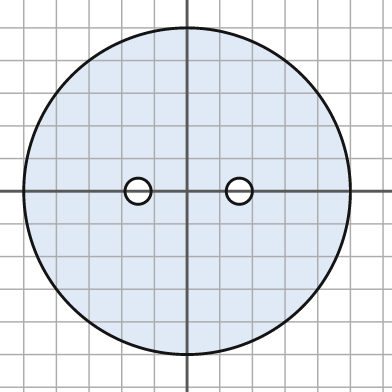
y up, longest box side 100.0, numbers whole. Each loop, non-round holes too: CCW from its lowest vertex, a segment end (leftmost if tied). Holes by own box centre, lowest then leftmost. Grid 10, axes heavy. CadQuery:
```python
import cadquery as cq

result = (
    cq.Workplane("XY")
    .moveTo(0.0, 0.0)
    .circle(50.0)
    .moveTo(-15.0, 0.0)
    .circle(4.0)
    .moveTo(16.0, 0.0)
    .circle(4.0)
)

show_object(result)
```